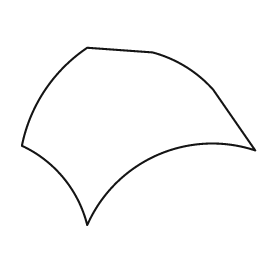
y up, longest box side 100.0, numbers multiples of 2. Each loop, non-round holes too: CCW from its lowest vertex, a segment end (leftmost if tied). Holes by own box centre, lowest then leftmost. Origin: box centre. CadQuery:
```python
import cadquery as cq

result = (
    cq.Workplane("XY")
    .moveTo(-22.0, -38.0)
    .threePointArc((8.0, -8.0), (50.0, -6.0))
    .lineTo(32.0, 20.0)
    .threePointArc((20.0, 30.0), (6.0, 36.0))
    .lineTo(-22.0, 38.0)
    .threePointArc((-40.0, 20.0), (-50.0, -4.0))
    .threePointArc((-32.0, -18.0), (-22.0, -38.0))
    .close()
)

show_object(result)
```